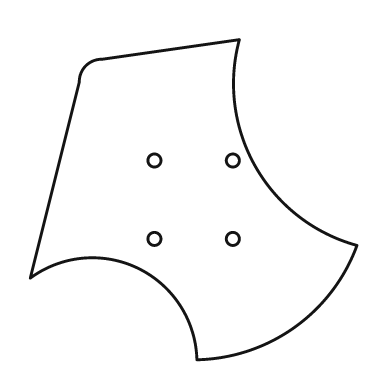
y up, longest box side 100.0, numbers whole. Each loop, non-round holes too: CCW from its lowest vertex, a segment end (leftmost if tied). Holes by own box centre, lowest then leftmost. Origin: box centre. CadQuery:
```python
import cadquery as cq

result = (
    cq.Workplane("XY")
    .moveTo(1.0, -49.0)
    .threePointArc((31.0, -39.0), (50.0, -14.0))
    .threePointArc((19.0, 10.0), (14.0, 49.0))
    .lineTo(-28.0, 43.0)
    .threePointArc((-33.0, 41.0), (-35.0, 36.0))
    .lineTo(-50.0, -24.0)
    .threePointArc((-17.0, -21.0), (1.0, -49.0))
    .close()
    .moveTo(-12.0, -12.0)
    .circle(2.0)
    .moveTo(12.0, -12.0)
    .circle(2.0)
    .moveTo(-12.0, 12.0)
    .circle(2.0)
    .moveTo(12.0, 12.0)
    .circle(2.0)
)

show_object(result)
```